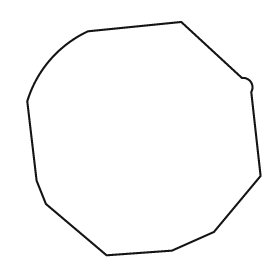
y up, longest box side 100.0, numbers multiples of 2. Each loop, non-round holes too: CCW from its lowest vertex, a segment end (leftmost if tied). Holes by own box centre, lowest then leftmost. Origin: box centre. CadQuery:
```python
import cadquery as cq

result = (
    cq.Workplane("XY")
    .moveTo(-16.0, -50.0)
    .lineTo(12.0, -48.0)
    .lineTo(30.0, -40.0)
    .lineTo(50.0, -16.0)
    .lineTo(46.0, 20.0)
    .threePointArc((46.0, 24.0), (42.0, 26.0))
    .lineTo(16.0, 50.0)
    .lineTo(-24.0, 46.0)
    .threePointArc((-40.0, 34.0), (-50.0, 16.0))
    .lineTo(-46.0, -18.0)
    .lineTo(-42.0, -28.0)
    .close()
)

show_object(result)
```